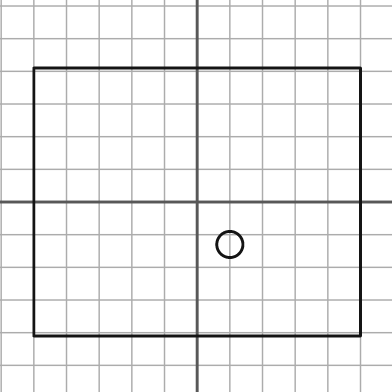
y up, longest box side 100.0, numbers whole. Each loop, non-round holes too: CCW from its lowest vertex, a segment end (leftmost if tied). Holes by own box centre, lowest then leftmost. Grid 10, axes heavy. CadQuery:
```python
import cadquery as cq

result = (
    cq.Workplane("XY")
    .moveTo(-50.0, -41.0)
    .lineTo(50.0, -41.0)
    .lineTo(50.0, 41.0)
    .lineTo(-50.0, 41.0)
    .close()
    .moveTo(10.0, -13.0)
    .circle(4.0)
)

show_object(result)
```